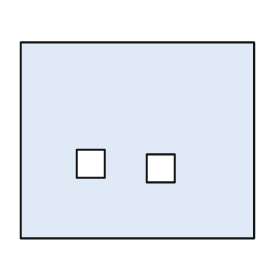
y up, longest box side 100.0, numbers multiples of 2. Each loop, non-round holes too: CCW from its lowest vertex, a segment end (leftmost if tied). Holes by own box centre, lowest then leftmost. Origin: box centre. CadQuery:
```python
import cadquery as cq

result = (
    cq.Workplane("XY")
    .moveTo(-50.0, -42.0)
    .lineTo(50.0, -42.0)
    .lineTo(50.0, 42.0)
    .lineTo(-50.0, 42.0)
    .close()
    .moveTo(4.0, -18.0)
    .lineTo(16.0, -18.0)
    .lineTo(16.0, -6.0)
    .lineTo(4.0, -6.0)
    .close()
    .moveTo(-26.0, -16.0)
    .lineTo(-14.0, -16.0)
    .lineTo(-14.0, -4.0)
    .lineTo(-26.0, -4.0)
    .close()
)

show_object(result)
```